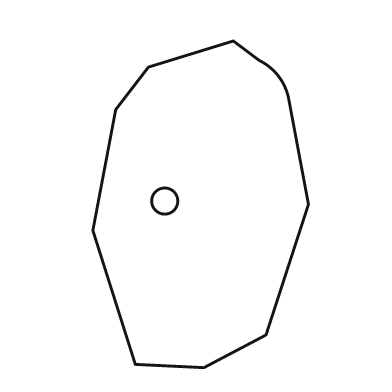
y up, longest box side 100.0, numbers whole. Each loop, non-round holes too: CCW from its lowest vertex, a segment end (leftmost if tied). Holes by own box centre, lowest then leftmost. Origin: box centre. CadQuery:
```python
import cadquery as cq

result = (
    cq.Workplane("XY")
    .moveTo(1.0, -50.0)
    .lineTo(20.0, -40.0)
    .lineTo(33.0, 0.0)
    .lineTo(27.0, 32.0)
    .threePointArc((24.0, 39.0), (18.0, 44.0))
    .lineTo(10.0, 50.0)
    .lineTo(-16.0, 42.0)
    .lineTo(-26.0, 29.0)
    .lineTo(-33.0, -8.0)
    .lineTo(-20.0, -49.0)
    .close()
    .moveTo(-11.0, 1.0)
    .circle(4.0)
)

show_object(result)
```